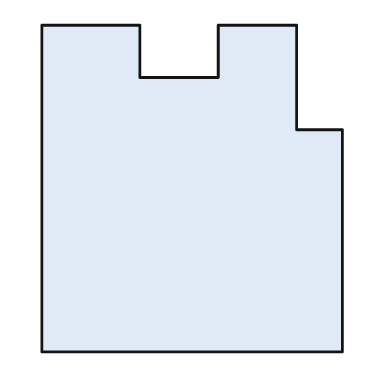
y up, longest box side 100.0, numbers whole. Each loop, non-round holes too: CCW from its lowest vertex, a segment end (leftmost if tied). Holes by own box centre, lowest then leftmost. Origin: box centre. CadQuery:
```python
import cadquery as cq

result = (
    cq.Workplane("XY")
    .moveTo(-46.0, -50.0)
    .lineTo(46.0, -50.0)
    .lineTo(46.0, 18.0)
    .lineTo(32.0, 18.0)
    .lineTo(32.0, 50.0)
    .lineTo(8.0, 50.0)
    .lineTo(8.0, 34.0)
    .lineTo(-16.0, 34.0)
    .lineTo(-16.0, 50.0)
    .lineTo(-46.0, 50.0)
    .close()
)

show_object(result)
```